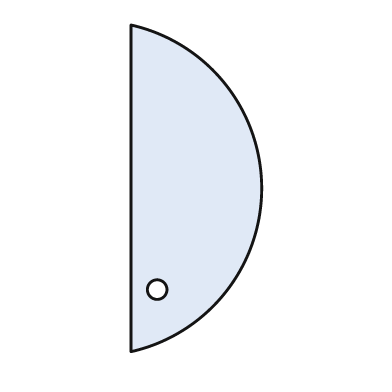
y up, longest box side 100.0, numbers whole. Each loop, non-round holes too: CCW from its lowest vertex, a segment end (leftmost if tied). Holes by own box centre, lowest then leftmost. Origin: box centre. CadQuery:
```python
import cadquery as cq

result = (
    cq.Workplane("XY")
    .moveTo(-20.0, -50.0)
    .threePointArc((20.0, 0.0), (-20.0, 50.0))
    .close()
    .moveTo(-12.0, -31.0)
    .circle(3.0)
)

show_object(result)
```